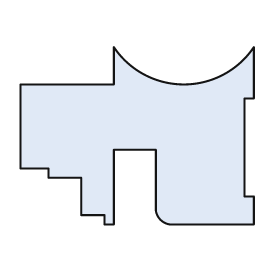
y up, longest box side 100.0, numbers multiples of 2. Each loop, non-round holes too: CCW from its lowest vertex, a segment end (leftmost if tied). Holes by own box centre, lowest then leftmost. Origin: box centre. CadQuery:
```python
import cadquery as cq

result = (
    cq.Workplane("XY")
    .moveTo(-14.0, -38.0)
    .lineTo(-10.0, -38.0)
    .lineTo(-10.0, -6.0)
    .lineTo(8.0, -6.0)
    .lineTo(8.0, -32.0)
    .threePointArc((10.0, -36.0), (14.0, -38.0))
    .lineTo(50.0, -38.0)
    .lineTo(50.0, -26.0)
    .lineTo(46.0, -26.0)
    .lineTo(46.0, 16.0)
    .lineTo(50.0, 16.0)
    .lineTo(50.0, 38.0)
    .threePointArc((20.0, 22.0), (-10.0, 38.0))
    .lineTo(-10.0, 22.0)
    .lineTo(-50.0, 22.0)
    .lineTo(-50.0, -14.0)
    .lineTo(-38.0, -14.0)
    .lineTo(-38.0, -18.0)
    .lineTo(-24.0, -18.0)
    .lineTo(-24.0, -34.0)
    .lineTo(-14.0, -34.0)
    .close()
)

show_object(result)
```